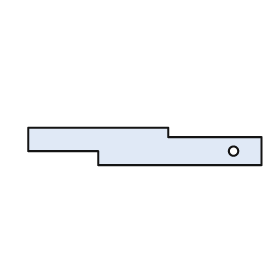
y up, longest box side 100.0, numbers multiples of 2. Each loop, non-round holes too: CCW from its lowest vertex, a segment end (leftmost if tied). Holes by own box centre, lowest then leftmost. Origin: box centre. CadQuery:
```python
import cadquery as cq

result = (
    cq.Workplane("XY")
    .moveTo(-20.0, -8.0)
    .lineTo(50.0, -8.0)
    .lineTo(50.0, 4.0)
    .lineTo(10.0, 4.0)
    .lineTo(10.0, 8.0)
    .lineTo(-50.0, 8.0)
    .lineTo(-50.0, -2.0)
    .lineTo(-20.0, -2.0)
    .close()
    .moveTo(38.0, -2.0)
    .circle(2.0)
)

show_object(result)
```